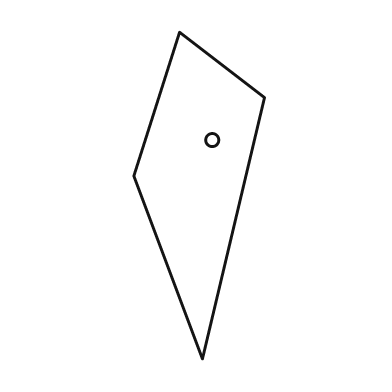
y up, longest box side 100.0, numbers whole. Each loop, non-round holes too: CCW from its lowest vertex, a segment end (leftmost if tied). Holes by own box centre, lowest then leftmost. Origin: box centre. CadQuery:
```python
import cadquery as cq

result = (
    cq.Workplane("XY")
    .moveTo(1.0, -50.0)
    .lineTo(20.0, 30.0)
    .lineTo(-6.0, 50.0)
    .lineTo(-20.0, 6.0)
    .close()
    .moveTo(4.0, 17.0)
    .circle(2.0)
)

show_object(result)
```